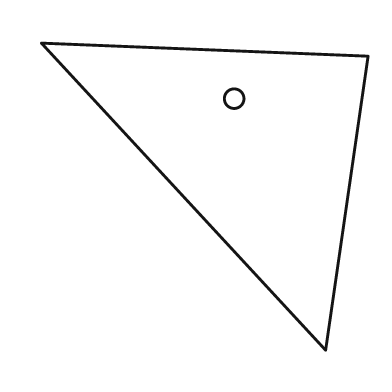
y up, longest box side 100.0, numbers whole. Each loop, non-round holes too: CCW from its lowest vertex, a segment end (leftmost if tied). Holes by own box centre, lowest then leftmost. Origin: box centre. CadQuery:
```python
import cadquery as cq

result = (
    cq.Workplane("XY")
    .moveTo(37.0, -47.0)
    .lineTo(50.0, 43.0)
    .lineTo(-50.0, 47.0)
    .close()
    .moveTo(9.0, 30.0)
    .circle(3.0)
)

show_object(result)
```